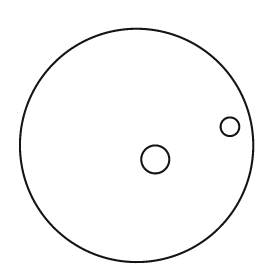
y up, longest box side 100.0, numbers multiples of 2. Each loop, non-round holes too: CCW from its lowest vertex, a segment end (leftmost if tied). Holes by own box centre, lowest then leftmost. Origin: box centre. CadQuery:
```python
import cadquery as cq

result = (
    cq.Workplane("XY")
    .moveTo(0.0, 0.0)
    .circle(50.0)
    .moveTo(8.0, -6.0)
    .circle(6.0)
    .moveTo(40.0, 8.0)
    .circle(4.0)
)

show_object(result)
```